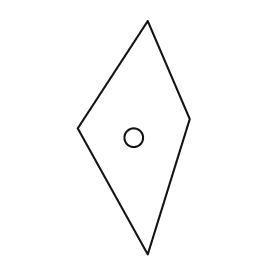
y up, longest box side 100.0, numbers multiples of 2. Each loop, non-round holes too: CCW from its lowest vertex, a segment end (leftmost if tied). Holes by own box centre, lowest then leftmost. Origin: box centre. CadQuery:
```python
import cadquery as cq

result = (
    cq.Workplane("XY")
    .moveTo(6.0, -50.0)
    .lineTo(24.0, 8.0)
    .lineTo(6.0, 50.0)
    .lineTo(-24.0, 4.0)
    .close()
    .moveTo(0.0, 0.0)
    .circle(4.0)
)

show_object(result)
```